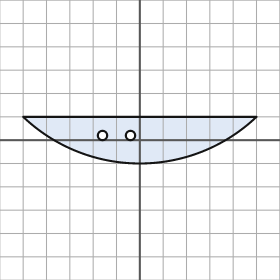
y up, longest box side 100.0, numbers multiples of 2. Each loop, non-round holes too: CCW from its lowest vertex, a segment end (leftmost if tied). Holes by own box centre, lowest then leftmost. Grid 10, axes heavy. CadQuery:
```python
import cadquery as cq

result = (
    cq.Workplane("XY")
    .moveTo(-50.0, 10.0)
    .threePointArc((0.0, -10.0), (50.0, 10.0))
    .close()
    .moveTo(-16.0, 2.0)
    .circle(2.0)
    .moveTo(-4.0, 2.0)
    .circle(2.0)
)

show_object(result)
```